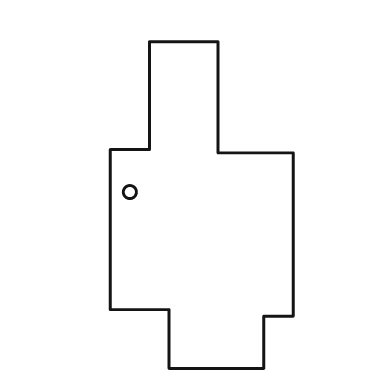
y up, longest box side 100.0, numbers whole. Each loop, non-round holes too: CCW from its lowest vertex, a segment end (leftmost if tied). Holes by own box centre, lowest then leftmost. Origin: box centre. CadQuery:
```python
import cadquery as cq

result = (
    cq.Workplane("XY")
    .moveTo(-10.0, -50.0)
    .lineTo(19.0, -50.0)
    .lineTo(19.0, -34.0)
    .lineTo(28.0, -34.0)
    .lineTo(28.0, 16.0)
    .lineTo(5.0, 16.0)
    .lineTo(5.0, 50.0)
    .lineTo(-16.0, 50.0)
    .lineTo(-16.0, 17.0)
    .lineTo(-28.0, 17.0)
    .lineTo(-28.0, -32.0)
    .lineTo(-10.0, -32.0)
    .close()
    .moveTo(-22.0, 4.0)
    .circle(2.0)
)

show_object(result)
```